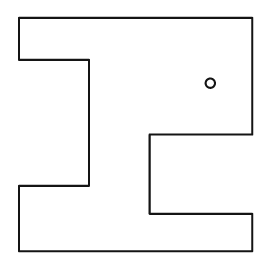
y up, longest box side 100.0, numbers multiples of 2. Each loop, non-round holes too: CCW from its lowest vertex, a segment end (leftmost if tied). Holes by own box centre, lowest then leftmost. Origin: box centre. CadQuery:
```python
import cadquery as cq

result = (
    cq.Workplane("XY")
    .moveTo(-50.0, -50.0)
    .lineTo(50.0, -50.0)
    .lineTo(50.0, -34.0)
    .lineTo(6.0, -34.0)
    .lineTo(6.0, 0.0)
    .lineTo(50.0, 0.0)
    .lineTo(50.0, 50.0)
    .lineTo(-50.0, 50.0)
    .lineTo(-50.0, 32.0)
    .lineTo(-20.0, 32.0)
    .lineTo(-20.0, -22.0)
    .lineTo(-50.0, -22.0)
    .close()
    .moveTo(32.0, 22.0)
    .circle(2.0)
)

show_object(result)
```